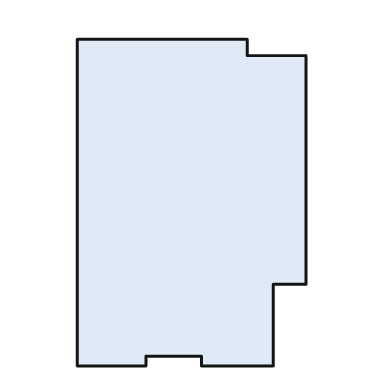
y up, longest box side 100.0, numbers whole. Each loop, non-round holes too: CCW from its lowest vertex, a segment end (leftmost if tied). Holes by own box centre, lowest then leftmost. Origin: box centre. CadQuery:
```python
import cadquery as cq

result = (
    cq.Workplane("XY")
    .moveTo(-35.0, -50.0)
    .lineTo(-14.0, -50.0)
    .lineTo(-14.0, -47.0)
    .lineTo(3.0, -47.0)
    .lineTo(3.0, -50.0)
    .lineTo(25.0, -50.0)
    .lineTo(25.0, -25.0)
    .lineTo(35.0, -25.0)
    .lineTo(35.0, 45.0)
    .lineTo(17.0, 45.0)
    .lineTo(17.0, 50.0)
    .lineTo(-35.0, 50.0)
    .close()
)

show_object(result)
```